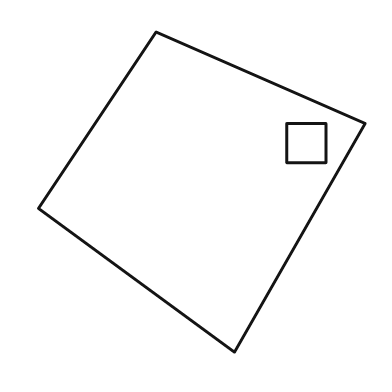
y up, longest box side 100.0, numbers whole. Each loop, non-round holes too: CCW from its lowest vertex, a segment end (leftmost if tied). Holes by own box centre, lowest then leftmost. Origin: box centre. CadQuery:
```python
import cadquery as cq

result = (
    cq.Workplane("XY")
    .moveTo(10.0, -49.0)
    .lineTo(50.0, 21.0)
    .lineTo(-14.0, 49.0)
    .lineTo(-50.0, -5.0)
    .close()
    .moveTo(26.0, 9.0)
    .lineTo(38.0, 9.0)
    .lineTo(38.0, 21.0)
    .lineTo(26.0, 21.0)
    .close()
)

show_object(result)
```